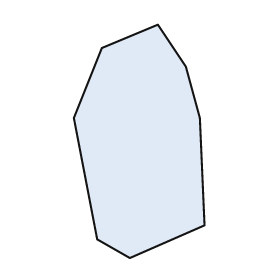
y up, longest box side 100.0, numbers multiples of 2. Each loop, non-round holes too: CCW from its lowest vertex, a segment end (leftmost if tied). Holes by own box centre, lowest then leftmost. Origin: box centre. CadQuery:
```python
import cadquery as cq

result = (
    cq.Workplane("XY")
    .moveTo(-4.0, -50.0)
    .lineTo(28.0, -36.0)
    .lineTo(26.0, 10.0)
    .lineTo(20.0, 32.0)
    .lineTo(8.0, 50.0)
    .lineTo(-16.0, 40.0)
    .lineTo(-28.0, 10.0)
    .lineTo(-18.0, -42.0)
    .close()
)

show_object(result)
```